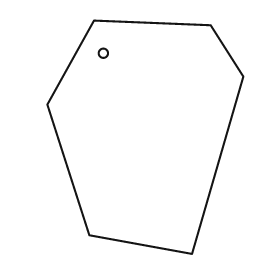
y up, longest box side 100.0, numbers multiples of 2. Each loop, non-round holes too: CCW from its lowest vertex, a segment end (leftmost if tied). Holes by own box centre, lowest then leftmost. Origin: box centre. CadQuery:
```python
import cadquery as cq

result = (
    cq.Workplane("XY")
    .moveTo(20.0, -50.0)
    .lineTo(42.0, 26.0)
    .lineTo(28.0, 48.0)
    .lineTo(-22.0, 50.0)
    .lineTo(-42.0, 14.0)
    .lineTo(-24.0, -42.0)
    .close()
    .moveTo(-18.0, 36.0)
    .circle(2.0)
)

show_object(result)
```